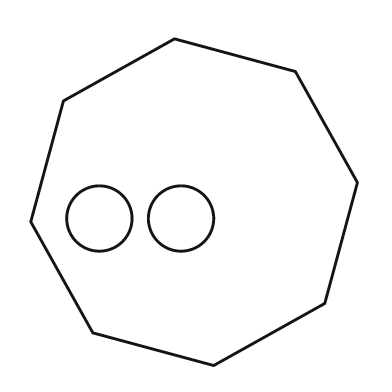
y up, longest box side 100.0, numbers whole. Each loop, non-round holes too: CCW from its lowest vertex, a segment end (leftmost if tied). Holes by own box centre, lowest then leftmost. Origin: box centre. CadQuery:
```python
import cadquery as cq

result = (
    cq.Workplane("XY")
    .moveTo(6.0, -50.0)
    .lineTo(40.0, -31.0)
    .lineTo(50.0, 6.0)
    .lineTo(31.0, 40.0)
    .lineTo(-6.0, 50.0)
    .lineTo(-40.0, 31.0)
    .lineTo(-50.0, -6.0)
    .lineTo(-31.0, -40.0)
    .close()
    .moveTo(-29.0, -5.0)
    .circle(10.0)
    .moveTo(-4.0, -5.0)
    .circle(10.0)
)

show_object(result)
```